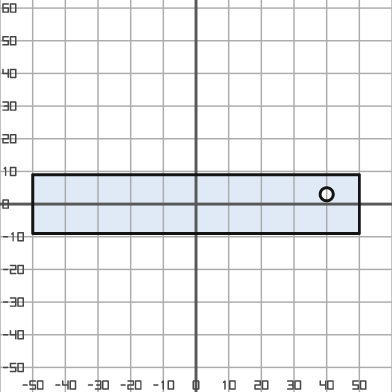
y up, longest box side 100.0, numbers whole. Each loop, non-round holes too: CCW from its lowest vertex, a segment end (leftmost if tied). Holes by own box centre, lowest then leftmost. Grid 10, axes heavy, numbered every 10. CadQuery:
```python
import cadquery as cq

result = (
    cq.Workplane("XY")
    .moveTo(-50.0, -9.0)
    .lineTo(50.0, -9.0)
    .lineTo(50.0, 9.0)
    .lineTo(-50.0, 9.0)
    .close()
    .moveTo(40.0, 3.0)
    .circle(2.0)
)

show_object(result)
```